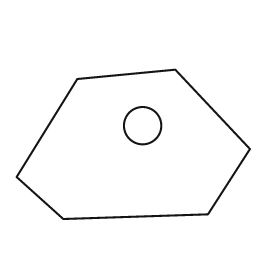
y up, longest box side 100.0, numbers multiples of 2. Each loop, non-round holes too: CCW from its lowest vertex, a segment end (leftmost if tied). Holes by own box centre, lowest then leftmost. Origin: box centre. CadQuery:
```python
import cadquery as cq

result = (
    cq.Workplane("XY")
    .moveTo(-30.0, -32.0)
    .lineTo(32.0, -30.0)
    .lineTo(50.0, -2.0)
    .lineTo(18.0, 32.0)
    .lineTo(-24.0, 28.0)
    .lineTo(-50.0, -14.0)
    .close()
    .moveTo(4.0, 8.0)
    .circle(8.0)
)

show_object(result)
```